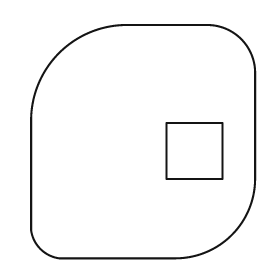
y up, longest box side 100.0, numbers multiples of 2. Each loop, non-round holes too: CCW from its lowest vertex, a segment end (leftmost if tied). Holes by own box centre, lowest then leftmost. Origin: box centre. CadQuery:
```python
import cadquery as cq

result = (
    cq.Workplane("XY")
    .moveTo(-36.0, -50.0)
    .lineTo(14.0, -50.0)
    .threePointArc((38.0, -40.0), (48.0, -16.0))
    .lineTo(48.0, 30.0)
    .threePointArc((42.0, 44.0), (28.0, 50.0))
    .lineTo(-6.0, 50.0)
    .threePointArc((-36.0, 38.0), (-48.0, 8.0))
    .lineTo(-48.0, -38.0)
    .threePointArc((-44.0, -46.0), (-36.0, -50.0))
    .close()
    .moveTo(10.0, -16.0)
    .lineTo(34.0, -16.0)
    .lineTo(34.0, 8.0)
    .lineTo(10.0, 8.0)
    .close()
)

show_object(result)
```